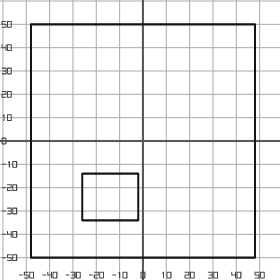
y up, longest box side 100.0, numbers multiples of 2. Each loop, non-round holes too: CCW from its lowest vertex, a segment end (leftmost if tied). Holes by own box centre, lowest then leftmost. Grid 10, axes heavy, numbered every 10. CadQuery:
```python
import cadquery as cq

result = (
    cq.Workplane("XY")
    .moveTo(-48.0, -50.0)
    .lineTo(48.0, -50.0)
    .lineTo(48.0, 50.0)
    .lineTo(-48.0, 50.0)
    .close()
    .moveTo(-26.0, -34.0)
    .lineTo(-2.0, -34.0)
    .lineTo(-2.0, -14.0)
    .lineTo(-26.0, -14.0)
    .close()
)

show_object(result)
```